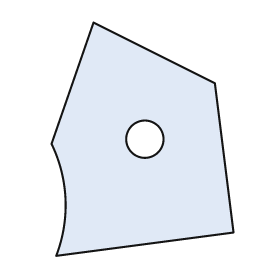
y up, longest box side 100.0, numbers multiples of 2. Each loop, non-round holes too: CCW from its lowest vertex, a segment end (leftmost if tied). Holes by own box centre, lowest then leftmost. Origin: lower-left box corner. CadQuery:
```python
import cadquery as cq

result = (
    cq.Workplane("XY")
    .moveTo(2.0, 0.0)
    .lineTo(78.0, 10.0)
    .lineTo(70.0, 74.0)
    .lineTo(18.0, 100.0)
    .lineTo(0.0, 48.0)
    .threePointArc((6.0, 24.0), (2.0, 0.0))
    .close()
    .moveTo(40.0, 50.0)
    .circle(8.0)
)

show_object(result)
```